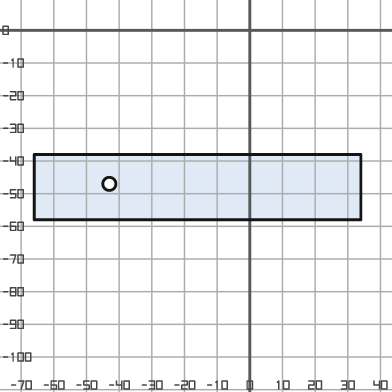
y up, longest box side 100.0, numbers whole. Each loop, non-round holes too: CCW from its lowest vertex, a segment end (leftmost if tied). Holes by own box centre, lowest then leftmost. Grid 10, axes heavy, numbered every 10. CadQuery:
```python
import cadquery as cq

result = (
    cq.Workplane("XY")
    .moveTo(-66.0, -58.0)
    .lineTo(34.0, -58.0)
    .lineTo(34.0, -38.0)
    .lineTo(-66.0, -38.0)
    .close()
    .moveTo(-43.0, -47.0)
    .circle(2.0)
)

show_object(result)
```